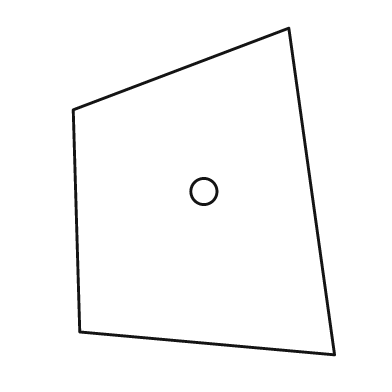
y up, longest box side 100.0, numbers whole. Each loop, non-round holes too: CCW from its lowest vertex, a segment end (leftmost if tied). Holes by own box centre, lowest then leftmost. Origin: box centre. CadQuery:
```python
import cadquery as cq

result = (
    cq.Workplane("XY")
    .moveTo(40.0, -50.0)
    .lineTo(26.0, 50.0)
    .lineTo(-40.0, 25.0)
    .lineTo(-38.0, -43.0)
    .close()
    .moveTo(0.0, 0.0)
    .circle(4.0)
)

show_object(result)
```